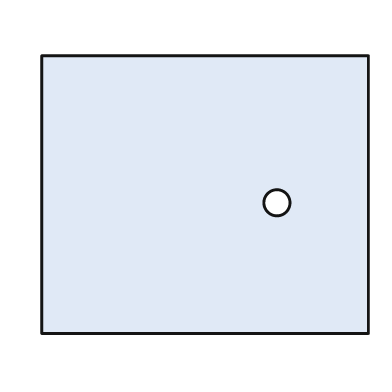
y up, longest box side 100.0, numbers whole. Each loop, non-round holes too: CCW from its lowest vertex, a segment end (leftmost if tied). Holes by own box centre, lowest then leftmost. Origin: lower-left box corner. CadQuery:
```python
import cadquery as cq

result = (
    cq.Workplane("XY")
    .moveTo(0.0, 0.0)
    .lineTo(100.0, 0.0)
    .lineTo(100.0, 85.0)
    .lineTo(0.0, 85.0)
    .close()
    .moveTo(72.0, 40.0)
    .circle(4.0)
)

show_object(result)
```